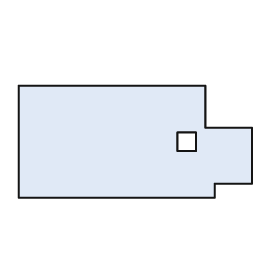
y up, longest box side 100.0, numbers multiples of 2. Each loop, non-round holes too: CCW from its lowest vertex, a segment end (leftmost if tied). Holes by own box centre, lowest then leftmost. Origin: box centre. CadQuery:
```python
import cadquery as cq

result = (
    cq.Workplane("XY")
    .moveTo(-50.0, -24.0)
    .lineTo(34.0, -24.0)
    .lineTo(34.0, -18.0)
    .lineTo(50.0, -18.0)
    .lineTo(50.0, 6.0)
    .lineTo(30.0, 6.0)
    .lineTo(30.0, 24.0)
    .lineTo(-50.0, 24.0)
    .close()
    .moveTo(18.0, -4.0)
    .lineTo(26.0, -4.0)
    .lineTo(26.0, 4.0)
    .lineTo(18.0, 4.0)
    .close()
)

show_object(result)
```